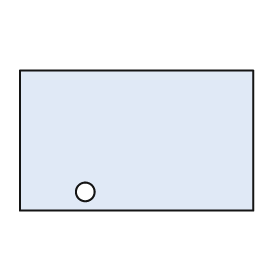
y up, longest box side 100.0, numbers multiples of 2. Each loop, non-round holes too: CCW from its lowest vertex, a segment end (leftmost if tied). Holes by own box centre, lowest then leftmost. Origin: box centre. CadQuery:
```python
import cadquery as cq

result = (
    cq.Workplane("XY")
    .moveTo(-50.0, -30.0)
    .lineTo(50.0, -30.0)
    .lineTo(50.0, 30.0)
    .lineTo(-50.0, 30.0)
    .close()
    .moveTo(-22.0, -22.0)
    .circle(4.0)
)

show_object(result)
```